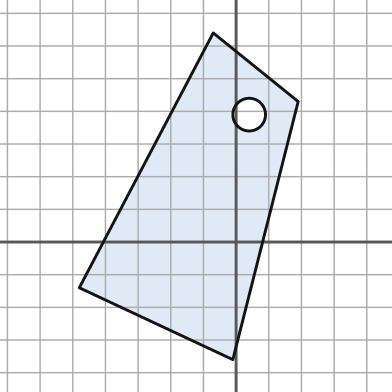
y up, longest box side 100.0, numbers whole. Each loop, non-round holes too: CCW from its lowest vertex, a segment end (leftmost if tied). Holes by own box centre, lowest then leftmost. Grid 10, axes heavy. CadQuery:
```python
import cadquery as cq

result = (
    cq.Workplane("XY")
    .moveTo(-1.0, -36.0)
    .lineTo(19.0, 43.0)
    .lineTo(-7.0, 64.0)
    .lineTo(-48.0, -14.0)
    .close()
    .moveTo(4.0, 39.0)
    .circle(5.0)
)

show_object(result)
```